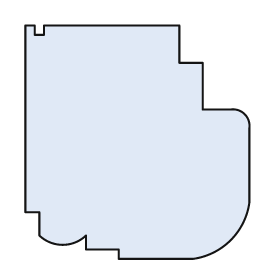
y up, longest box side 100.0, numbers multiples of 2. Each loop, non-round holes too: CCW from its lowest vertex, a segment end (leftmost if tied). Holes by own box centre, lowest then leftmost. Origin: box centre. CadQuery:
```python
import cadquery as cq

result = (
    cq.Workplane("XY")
    .moveTo(-8.0, -50.0)
    .lineTo(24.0, -50.0)
    .threePointArc((40.0, -42.0), (48.0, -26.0))
    .lineTo(48.0, 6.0)
    .threePointArc((46.0, 12.0), (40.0, 14.0))
    .lineTo(28.0, 14.0)
    .lineTo(28.0, 34.0)
    .lineTo(18.0, 34.0)
    .lineTo(18.0, 50.0)
    .lineTo(-40.0, 50.0)
    .lineTo(-40.0, 46.0)
    .lineTo(-44.0, 46.0)
    .lineTo(-44.0, 50.0)
    .lineTo(-48.0, 50.0)
    .lineTo(-48.0, -30.0)
    .lineTo(-42.0, -30.0)
    .lineTo(-42.0, -40.0)
    .threePointArc((-32.0, -44.0), (-22.0, -40.0))
    .lineTo(-22.0, -46.0)
    .lineTo(-8.0, -46.0)
    .close()
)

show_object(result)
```